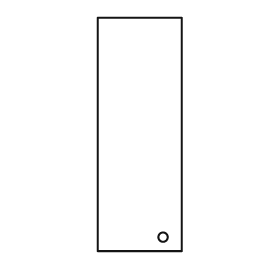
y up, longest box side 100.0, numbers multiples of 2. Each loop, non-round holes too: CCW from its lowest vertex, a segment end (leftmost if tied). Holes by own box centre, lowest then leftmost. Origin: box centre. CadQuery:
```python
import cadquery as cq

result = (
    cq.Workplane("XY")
    .moveTo(-18.0, -50.0)
    .lineTo(18.0, -50.0)
    .lineTo(18.0, 50.0)
    .lineTo(-18.0, 50.0)
    .close()
    .moveTo(10.0, -44.0)
    .circle(2.0)
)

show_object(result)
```